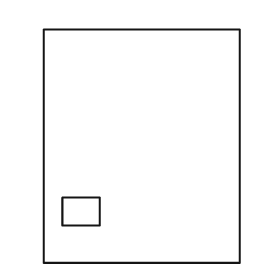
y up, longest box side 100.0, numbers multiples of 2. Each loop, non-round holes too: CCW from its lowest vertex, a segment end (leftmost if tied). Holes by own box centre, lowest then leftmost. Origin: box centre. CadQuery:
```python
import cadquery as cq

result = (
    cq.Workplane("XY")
    .moveTo(-42.0, -50.0)
    .lineTo(42.0, -50.0)
    .lineTo(42.0, 50.0)
    .lineTo(-42.0, 50.0)
    .close()
    .moveTo(-34.0, -34.0)
    .lineTo(-18.0, -34.0)
    .lineTo(-18.0, -22.0)
    .lineTo(-34.0, -22.0)
    .close()
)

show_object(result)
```